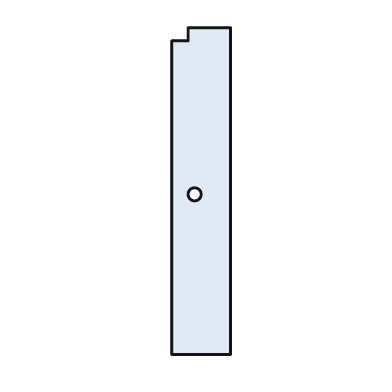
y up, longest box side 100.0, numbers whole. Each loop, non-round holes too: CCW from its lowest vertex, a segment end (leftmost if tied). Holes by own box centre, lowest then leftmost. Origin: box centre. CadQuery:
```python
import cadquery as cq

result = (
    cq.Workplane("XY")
    .moveTo(-9.0, -50.0)
    .lineTo(9.0, -50.0)
    .lineTo(9.0, 50.0)
    .lineTo(-4.0, 50.0)
    .lineTo(-4.0, 46.0)
    .lineTo(-9.0, 46.0)
    .close()
    .moveTo(-2.0, -1.0)
    .circle(2.0)
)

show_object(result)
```